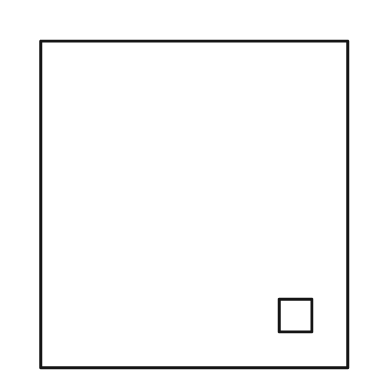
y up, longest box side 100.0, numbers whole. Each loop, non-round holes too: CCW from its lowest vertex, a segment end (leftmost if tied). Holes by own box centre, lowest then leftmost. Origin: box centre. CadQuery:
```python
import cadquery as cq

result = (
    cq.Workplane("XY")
    .moveTo(-47.0, -50.0)
    .lineTo(47.0, -50.0)
    .lineTo(47.0, 50.0)
    .lineTo(-47.0, 50.0)
    .close()
    .moveTo(26.0, -39.0)
    .lineTo(36.0, -39.0)
    .lineTo(36.0, -29.0)
    .lineTo(26.0, -29.0)
    .close()
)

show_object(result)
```